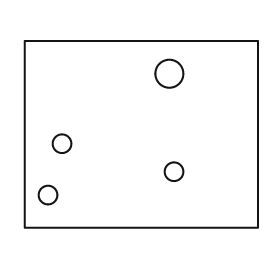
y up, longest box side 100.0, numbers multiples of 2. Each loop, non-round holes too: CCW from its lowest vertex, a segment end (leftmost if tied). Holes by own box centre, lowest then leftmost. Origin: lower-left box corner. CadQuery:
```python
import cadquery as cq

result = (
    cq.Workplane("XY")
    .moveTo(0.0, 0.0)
    .lineTo(100.0, 0.0)
    .lineTo(100.0, 80.0)
    .lineTo(0.0, 80.0)
    .close()
    .moveTo(10.0, 14.0)
    .circle(4.0)
    .moveTo(64.0, 24.0)
    .circle(4.0)
    .moveTo(16.0, 36.0)
    .circle(4.0)
    .moveTo(62.0, 66.0)
    .circle(6.0)
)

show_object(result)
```